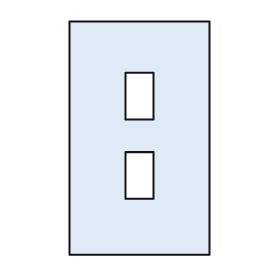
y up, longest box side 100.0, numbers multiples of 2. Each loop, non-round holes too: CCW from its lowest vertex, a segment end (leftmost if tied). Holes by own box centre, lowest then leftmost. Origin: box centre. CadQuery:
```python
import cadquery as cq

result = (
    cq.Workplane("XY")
    .moveTo(-30.0, -50.0)
    .lineTo(30.0, -50.0)
    .lineTo(30.0, 50.0)
    .lineTo(-30.0, 50.0)
    .close()
    .moveTo(-6.0, -26.0)
    .lineTo(6.0, -26.0)
    .lineTo(6.0, -6.0)
    .lineTo(-6.0, -6.0)
    .close()
    .moveTo(-6.0, 8.0)
    .lineTo(6.0, 8.0)
    .lineTo(6.0, 28.0)
    .lineTo(-6.0, 28.0)
    .close()
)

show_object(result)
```